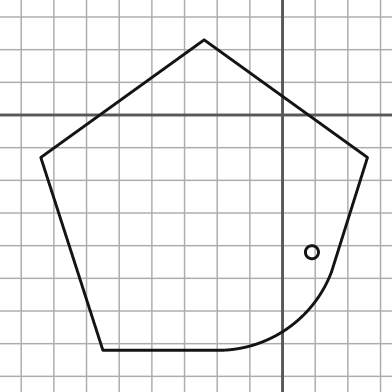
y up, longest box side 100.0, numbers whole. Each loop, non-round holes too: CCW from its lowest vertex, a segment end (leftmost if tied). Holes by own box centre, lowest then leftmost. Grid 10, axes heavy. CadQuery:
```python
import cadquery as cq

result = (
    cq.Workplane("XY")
    .moveTo(-55.0, -72.0)
    .lineTo(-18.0, -72.0)
    .threePointArc((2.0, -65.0), (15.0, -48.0))
    .lineTo(26.0, -13.0)
    .lineTo(-24.0, 23.0)
    .lineTo(-74.0, -13.0)
    .close()
    .moveTo(9.0, -42.0)
    .circle(2.0)
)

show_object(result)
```